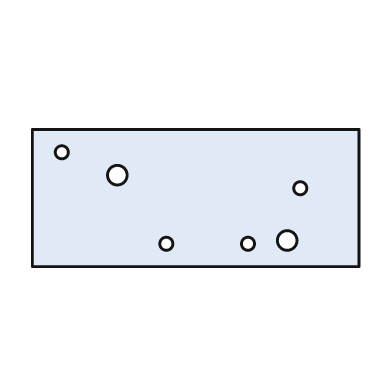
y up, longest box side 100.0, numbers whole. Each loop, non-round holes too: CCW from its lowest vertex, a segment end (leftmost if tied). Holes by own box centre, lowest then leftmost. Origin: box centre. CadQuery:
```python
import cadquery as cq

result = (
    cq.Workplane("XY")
    .moveTo(-50.0, -21.0)
    .lineTo(50.0, -21.0)
    .lineTo(50.0, 21.0)
    .lineTo(-50.0, 21.0)
    .close()
    .moveTo(-9.0, -14.0)
    .circle(2.0)
    .moveTo(16.0, -14.0)
    .circle(2.0)
    .moveTo(28.0, -13.0)
    .circle(3.0)
    .moveTo(32.0, 3.0)
    .circle(2.0)
    .moveTo(-24.0, 7.0)
    .circle(3.0)
    .moveTo(-41.0, 14.0)
    .circle(2.0)
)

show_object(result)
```